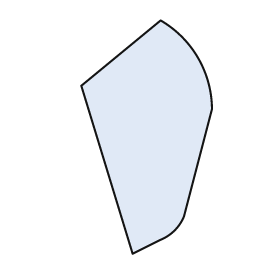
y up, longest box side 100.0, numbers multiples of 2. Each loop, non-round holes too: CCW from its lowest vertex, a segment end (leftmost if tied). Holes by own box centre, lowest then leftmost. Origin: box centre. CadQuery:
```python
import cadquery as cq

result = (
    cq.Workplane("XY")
    .moveTo(-6.0, -50.0)
    .lineTo(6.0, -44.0)
    .threePointArc((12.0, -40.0), (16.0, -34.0))
    .lineTo(28.0, 12.0)
    .threePointArc((22.0, 34.0), (6.0, 50.0))
    .lineTo(-28.0, 22.0)
    .close()
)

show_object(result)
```